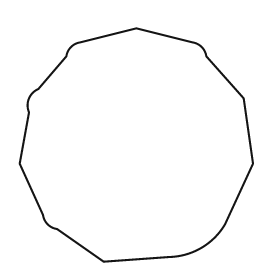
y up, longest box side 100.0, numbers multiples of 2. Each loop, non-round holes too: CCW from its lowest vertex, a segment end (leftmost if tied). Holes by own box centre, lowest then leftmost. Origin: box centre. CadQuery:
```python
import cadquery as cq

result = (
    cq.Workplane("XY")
    .moveTo(-14.0, -50.0)
    .lineTo(14.0, -48.0)
    .threePointArc((28.0, -44.0), (38.0, -34.0))
    .lineTo(50.0, -8.0)
    .lineTo(46.0, 20.0)
    .lineTo(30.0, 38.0)
    .threePointArc((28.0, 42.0), (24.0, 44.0))
    .lineTo(0.0, 50.0)
    .lineTo(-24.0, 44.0)
    .threePointArc((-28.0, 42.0), (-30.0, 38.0))
    .lineTo(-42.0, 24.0)
    .threePointArc((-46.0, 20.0), (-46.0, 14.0))
    .lineTo(-50.0, -8.0)
    .lineTo(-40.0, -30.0)
    .threePointArc((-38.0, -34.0), (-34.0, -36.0))
    .close()
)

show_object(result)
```